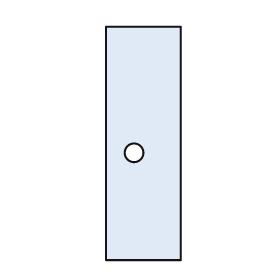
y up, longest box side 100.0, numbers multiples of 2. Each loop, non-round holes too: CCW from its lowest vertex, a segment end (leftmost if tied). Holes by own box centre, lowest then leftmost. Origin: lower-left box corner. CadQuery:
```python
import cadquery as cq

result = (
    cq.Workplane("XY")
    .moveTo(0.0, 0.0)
    .lineTo(32.0, 0.0)
    .lineTo(32.0, 100.0)
    .lineTo(0.0, 100.0)
    .close()
    .moveTo(12.0, 46.0)
    .circle(4.0)
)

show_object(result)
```